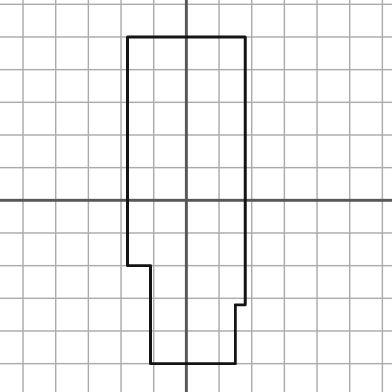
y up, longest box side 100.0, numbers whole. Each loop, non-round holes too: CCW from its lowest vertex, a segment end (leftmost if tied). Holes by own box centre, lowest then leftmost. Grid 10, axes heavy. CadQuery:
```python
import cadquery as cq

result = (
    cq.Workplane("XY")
    .moveTo(-11.0, -50.0)
    .lineTo(15.0, -50.0)
    .lineTo(15.0, -32.0)
    .lineTo(18.0, -32.0)
    .lineTo(18.0, 50.0)
    .lineTo(-18.0, 50.0)
    .lineTo(-18.0, -20.0)
    .lineTo(-11.0, -20.0)
    .close()
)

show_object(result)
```